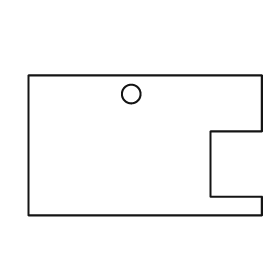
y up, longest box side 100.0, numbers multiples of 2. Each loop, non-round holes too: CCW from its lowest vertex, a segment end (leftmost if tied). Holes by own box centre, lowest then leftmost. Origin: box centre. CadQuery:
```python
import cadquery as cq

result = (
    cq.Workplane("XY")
    .moveTo(-50.0, -30.0)
    .lineTo(50.0, -30.0)
    .lineTo(50.0, -22.0)
    .lineTo(28.0, -22.0)
    .lineTo(28.0, 6.0)
    .lineTo(50.0, 6.0)
    .lineTo(50.0, 30.0)
    .lineTo(-50.0, 30.0)
    .close()
    .moveTo(-6.0, 22.0)
    .circle(4.0)
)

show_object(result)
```